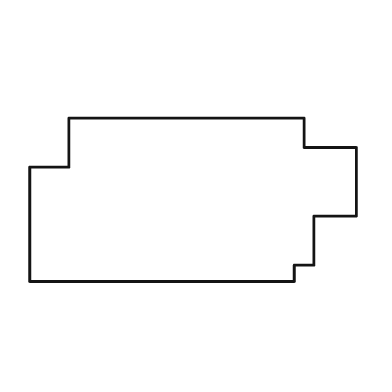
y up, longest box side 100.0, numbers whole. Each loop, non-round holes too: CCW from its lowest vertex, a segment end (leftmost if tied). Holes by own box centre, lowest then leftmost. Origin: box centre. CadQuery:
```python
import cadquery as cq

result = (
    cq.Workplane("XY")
    .moveTo(-50.0, -25.0)
    .lineTo(31.0, -25.0)
    .lineTo(31.0, -20.0)
    .lineTo(37.0, -20.0)
    .lineTo(37.0, -5.0)
    .lineTo(50.0, -5.0)
    .lineTo(50.0, 16.0)
    .lineTo(34.0, 16.0)
    .lineTo(34.0, 25.0)
    .lineTo(-38.0, 25.0)
    .lineTo(-38.0, 10.0)
    .lineTo(-50.0, 10.0)
    .close()
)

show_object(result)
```